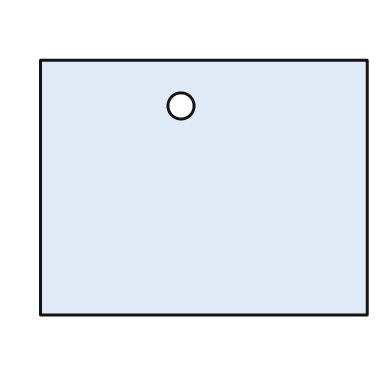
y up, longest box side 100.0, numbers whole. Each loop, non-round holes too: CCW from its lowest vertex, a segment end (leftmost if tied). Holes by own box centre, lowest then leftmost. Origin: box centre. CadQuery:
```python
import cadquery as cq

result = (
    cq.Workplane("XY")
    .moveTo(-50.0, -39.0)
    .lineTo(50.0, -39.0)
    .lineTo(50.0, 39.0)
    .lineTo(-50.0, 39.0)
    .close()
    .moveTo(-7.0, 25.0)
    .circle(4.0)
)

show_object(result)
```